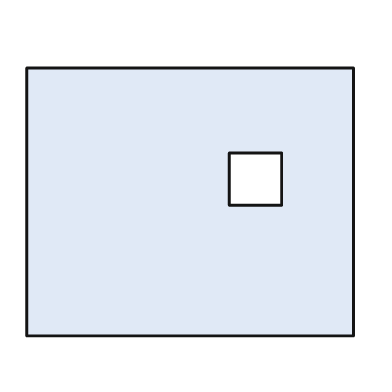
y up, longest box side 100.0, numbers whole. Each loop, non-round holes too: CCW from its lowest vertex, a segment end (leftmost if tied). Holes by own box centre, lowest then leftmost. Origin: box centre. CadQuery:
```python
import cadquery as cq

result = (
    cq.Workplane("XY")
    .moveTo(-50.0, -41.0)
    .lineTo(50.0, -41.0)
    .lineTo(50.0, 41.0)
    .lineTo(-50.0, 41.0)
    .close()
    .moveTo(12.0, -1.0)
    .lineTo(28.0, -1.0)
    .lineTo(28.0, 15.0)
    .lineTo(12.0, 15.0)
    .close()
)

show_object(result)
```